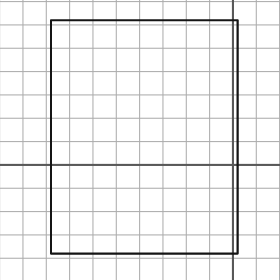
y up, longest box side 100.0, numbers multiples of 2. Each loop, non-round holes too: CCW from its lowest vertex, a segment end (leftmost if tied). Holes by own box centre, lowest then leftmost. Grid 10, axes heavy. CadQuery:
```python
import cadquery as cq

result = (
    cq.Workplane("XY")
    .moveTo(-78.0, -38.0)
    .lineTo(2.0, -38.0)
    .lineTo(2.0, 62.0)
    .lineTo(-78.0, 62.0)
    .close()
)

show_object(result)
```